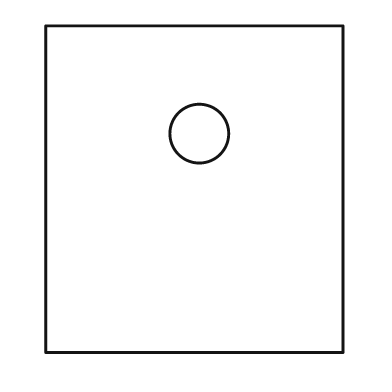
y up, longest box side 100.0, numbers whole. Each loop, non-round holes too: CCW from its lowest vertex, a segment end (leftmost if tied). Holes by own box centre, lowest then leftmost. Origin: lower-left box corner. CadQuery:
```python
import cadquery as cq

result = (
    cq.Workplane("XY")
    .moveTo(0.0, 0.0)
    .lineTo(91.0, 0.0)
    .lineTo(91.0, 100.0)
    .lineTo(0.0, 100.0)
    .close()
    .moveTo(47.0, 67.0)
    .circle(9.0)
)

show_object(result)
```